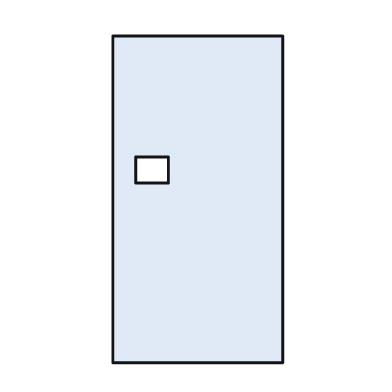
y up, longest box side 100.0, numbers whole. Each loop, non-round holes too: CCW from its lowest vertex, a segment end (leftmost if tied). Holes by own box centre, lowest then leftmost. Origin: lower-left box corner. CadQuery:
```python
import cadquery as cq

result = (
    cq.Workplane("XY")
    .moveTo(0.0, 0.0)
    .lineTo(52.0, 0.0)
    .lineTo(52.0, 100.0)
    .lineTo(0.0, 100.0)
    .close()
    .moveTo(7.0, 55.0)
    .lineTo(17.0, 55.0)
    .lineTo(17.0, 63.0)
    .lineTo(7.0, 63.0)
    .close()
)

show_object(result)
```